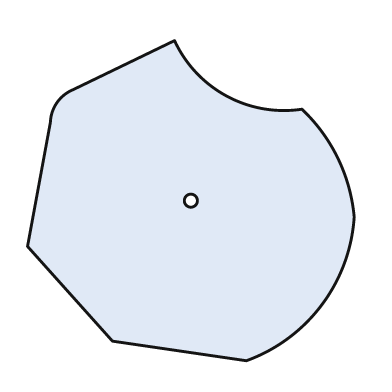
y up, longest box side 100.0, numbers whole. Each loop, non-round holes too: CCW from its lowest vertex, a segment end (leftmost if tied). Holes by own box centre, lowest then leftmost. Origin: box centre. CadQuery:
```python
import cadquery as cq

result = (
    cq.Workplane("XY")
    .moveTo(17.0, -49.0)
    .threePointArc((40.0, -32.0), (50.0, -5.0))
    .threePointArc((45.0, 13.0), (34.0, 28.0))
    .threePointArc((11.0, 32.0), (-5.0, 49.0))
    .lineTo(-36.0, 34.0)
    .threePointArc((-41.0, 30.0), (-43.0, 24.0))
    .lineTo(-50.0, -14.0)
    .lineTo(-24.0, -43.0)
    .close()
    .moveTo(0.0, 0.0)
    .circle(2.0)
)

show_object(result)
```